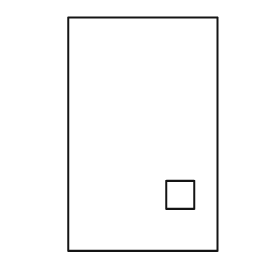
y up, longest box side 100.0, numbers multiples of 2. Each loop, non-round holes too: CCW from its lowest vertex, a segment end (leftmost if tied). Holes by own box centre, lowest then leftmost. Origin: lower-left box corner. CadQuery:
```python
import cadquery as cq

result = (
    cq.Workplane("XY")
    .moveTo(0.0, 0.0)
    .lineTo(64.0, 0.0)
    .lineTo(64.0, 100.0)
    .lineTo(0.0, 100.0)
    .close()
    .moveTo(42.0, 18.0)
    .lineTo(54.0, 18.0)
    .lineTo(54.0, 30.0)
    .lineTo(42.0, 30.0)
    .close()
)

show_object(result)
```